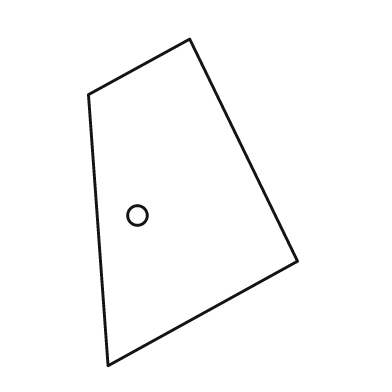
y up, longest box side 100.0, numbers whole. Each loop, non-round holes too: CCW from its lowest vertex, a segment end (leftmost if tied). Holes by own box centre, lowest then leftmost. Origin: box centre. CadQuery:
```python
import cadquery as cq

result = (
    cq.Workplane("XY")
    .moveTo(-26.0, -50.0)
    .lineTo(32.0, -18.0)
    .lineTo(-1.0, 50.0)
    .lineTo(-32.0, 33.0)
    .close()
    .moveTo(-17.0, -4.0)
    .circle(3.0)
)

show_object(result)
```